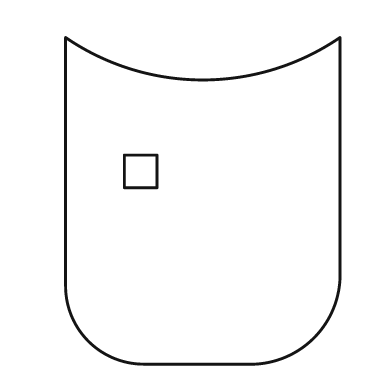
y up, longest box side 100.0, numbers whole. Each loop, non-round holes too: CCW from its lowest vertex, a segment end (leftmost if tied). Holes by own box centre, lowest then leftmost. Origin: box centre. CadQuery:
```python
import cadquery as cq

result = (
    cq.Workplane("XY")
    .moveTo(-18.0, -50.0)
    .lineTo(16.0, -50.0)
    .threePointArc((34.0, -42.0), (42.0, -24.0))
    .lineTo(42.0, 50.0)
    .threePointArc((0.0, 37.0), (-42.0, 50.0))
    .lineTo(-42.0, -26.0)
    .threePointArc((-35.0, -43.0), (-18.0, -50.0))
    .close()
    .moveTo(-24.0, 4.0)
    .lineTo(-14.0, 4.0)
    .lineTo(-14.0, 14.0)
    .lineTo(-24.0, 14.0)
    .close()
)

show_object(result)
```